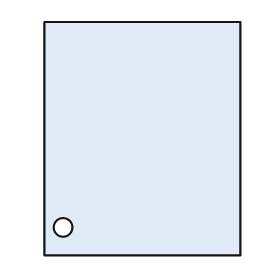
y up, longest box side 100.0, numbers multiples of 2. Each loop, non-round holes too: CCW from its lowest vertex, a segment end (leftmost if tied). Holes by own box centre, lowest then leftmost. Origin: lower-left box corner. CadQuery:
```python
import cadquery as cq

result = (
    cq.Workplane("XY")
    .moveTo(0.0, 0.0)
    .lineTo(84.0, 0.0)
    .lineTo(84.0, 100.0)
    .lineTo(0.0, 100.0)
    .close()
    .moveTo(8.0, 12.0)
    .circle(4.0)
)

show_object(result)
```